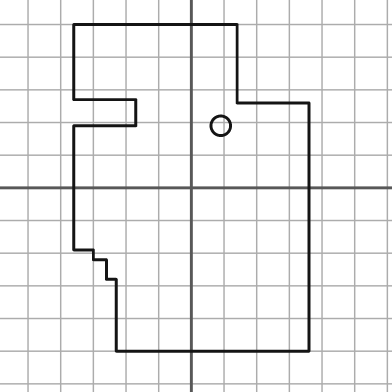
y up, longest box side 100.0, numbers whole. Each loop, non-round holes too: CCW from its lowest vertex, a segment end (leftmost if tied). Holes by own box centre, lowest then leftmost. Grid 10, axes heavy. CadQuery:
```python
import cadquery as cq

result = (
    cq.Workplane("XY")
    .moveTo(-23.0, -50.0)
    .lineTo(36.0, -50.0)
    .lineTo(36.0, 26.0)
    .lineTo(14.0, 26.0)
    .lineTo(14.0, 50.0)
    .lineTo(-36.0, 50.0)
    .lineTo(-36.0, 27.0)
    .lineTo(-17.0, 27.0)
    .lineTo(-17.0, 19.0)
    .lineTo(-36.0, 19.0)
    .lineTo(-36.0, -19.0)
    .lineTo(-30.0, -19.0)
    .lineTo(-30.0, -22.0)
    .lineTo(-26.0, -22.0)
    .lineTo(-26.0, -28.0)
    .lineTo(-23.0, -28.0)
    .close()
    .moveTo(9.0, 19.0)
    .circle(3.0)
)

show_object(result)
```